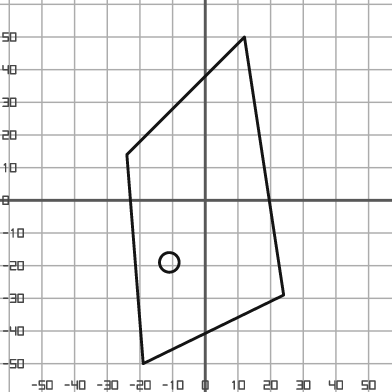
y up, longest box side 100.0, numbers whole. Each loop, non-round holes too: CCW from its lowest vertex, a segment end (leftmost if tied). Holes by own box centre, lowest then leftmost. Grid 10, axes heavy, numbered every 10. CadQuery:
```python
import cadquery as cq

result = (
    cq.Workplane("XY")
    .moveTo(-19.0, -50.0)
    .lineTo(24.0, -29.0)
    .lineTo(12.0, 50.0)
    .lineTo(-24.0, 14.0)
    .close()
    .moveTo(-11.0, -19.0)
    .circle(3.0)
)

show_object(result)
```